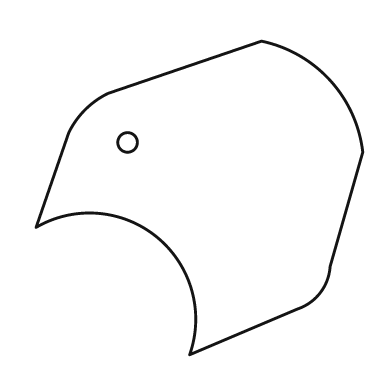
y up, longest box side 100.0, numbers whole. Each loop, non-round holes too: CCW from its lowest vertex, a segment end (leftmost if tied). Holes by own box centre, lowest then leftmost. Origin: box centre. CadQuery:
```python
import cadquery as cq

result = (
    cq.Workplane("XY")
    .moveTo(-3.0, -48.0)
    .lineTo(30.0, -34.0)
    .threePointArc((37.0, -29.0), (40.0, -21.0))
    .lineTo(50.0, 14.0)
    .threePointArc((40.0, 36.0), (19.0, 48.0))
    .lineTo(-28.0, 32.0)
    .threePointArc((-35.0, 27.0), (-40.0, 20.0))
    .lineTo(-50.0, -9.0)
    .threePointArc((-13.0, -12.0), (-3.0, -48.0))
    .close()
    .moveTo(-22.0, 17.0)
    .circle(3.0)
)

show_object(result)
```